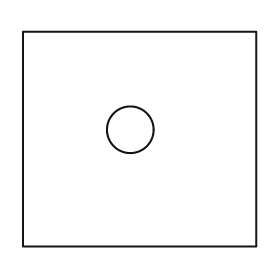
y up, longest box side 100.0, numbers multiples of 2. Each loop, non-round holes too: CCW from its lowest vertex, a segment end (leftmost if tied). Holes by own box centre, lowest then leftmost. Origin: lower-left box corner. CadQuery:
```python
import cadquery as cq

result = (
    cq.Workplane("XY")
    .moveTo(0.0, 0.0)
    .lineTo(100.0, 0.0)
    .lineTo(100.0, 92.0)
    .lineTo(0.0, 92.0)
    .close()
    .moveTo(46.0, 50.0)
    .circle(10.0)
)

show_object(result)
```